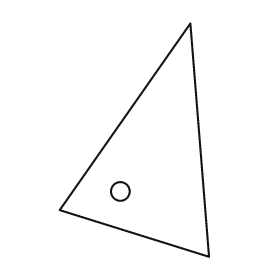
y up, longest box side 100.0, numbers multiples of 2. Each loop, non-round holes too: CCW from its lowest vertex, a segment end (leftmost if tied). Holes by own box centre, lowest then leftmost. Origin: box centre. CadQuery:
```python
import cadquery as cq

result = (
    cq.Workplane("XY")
    .moveTo(32.0, -50.0)
    .lineTo(24.0, 50.0)
    .lineTo(-32.0, -30.0)
    .close()
    .moveTo(-6.0, -22.0)
    .circle(4.0)
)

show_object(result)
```